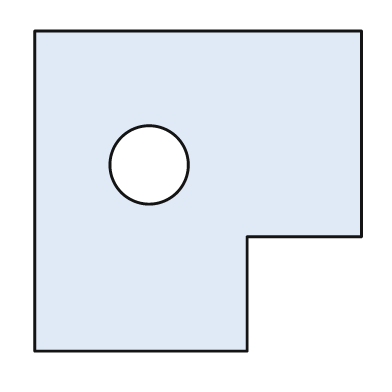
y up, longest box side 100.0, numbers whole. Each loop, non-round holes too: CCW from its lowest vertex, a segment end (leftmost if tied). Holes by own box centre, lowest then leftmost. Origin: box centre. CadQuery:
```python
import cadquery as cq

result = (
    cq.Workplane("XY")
    .moveTo(-50.0, -49.0)
    .lineTo(15.0, -49.0)
    .lineTo(15.0, -14.0)
    .lineTo(50.0, -14.0)
    .lineTo(50.0, 49.0)
    .lineTo(-50.0, 49.0)
    .close()
    .moveTo(-15.0, 8.0)
    .circle(12.0)
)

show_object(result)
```